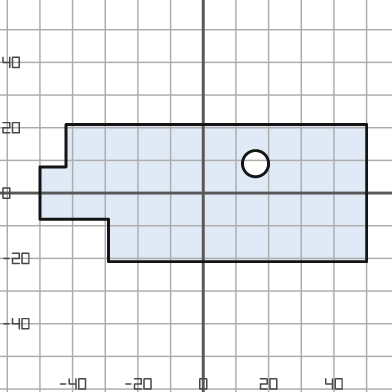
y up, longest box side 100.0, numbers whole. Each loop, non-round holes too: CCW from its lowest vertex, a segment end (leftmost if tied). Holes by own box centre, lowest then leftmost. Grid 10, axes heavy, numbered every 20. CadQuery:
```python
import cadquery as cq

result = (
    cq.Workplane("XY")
    .moveTo(-29.0, -21.0)
    .lineTo(50.0, -21.0)
    .lineTo(50.0, 21.0)
    .lineTo(-42.0, 21.0)
    .lineTo(-42.0, 8.0)
    .lineTo(-50.0, 8.0)
    .lineTo(-50.0, -8.0)
    .lineTo(-29.0, -8.0)
    .close()
    .moveTo(16.0, 9.0)
    .circle(4.0)
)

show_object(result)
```